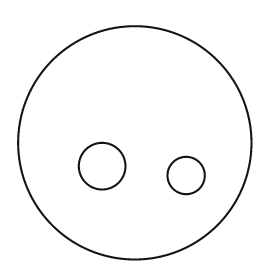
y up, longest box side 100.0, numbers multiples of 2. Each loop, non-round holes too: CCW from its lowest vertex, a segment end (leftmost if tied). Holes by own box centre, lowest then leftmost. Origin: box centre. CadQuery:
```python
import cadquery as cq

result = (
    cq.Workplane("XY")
    .moveTo(0.0, 0.0)
    .circle(50.0)
    .moveTo(22.0, -14.0)
    .circle(8.0)
    .moveTo(-14.0, -10.0)
    .circle(10.0)
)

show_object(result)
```